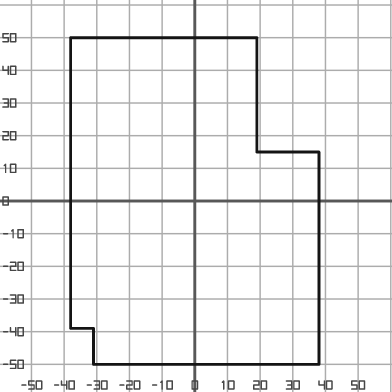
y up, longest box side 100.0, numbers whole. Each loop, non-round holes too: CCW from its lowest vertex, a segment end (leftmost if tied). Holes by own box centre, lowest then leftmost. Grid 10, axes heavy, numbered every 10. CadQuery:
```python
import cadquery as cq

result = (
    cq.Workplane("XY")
    .moveTo(-31.0, -50.0)
    .lineTo(38.0, -50.0)
    .lineTo(38.0, 15.0)
    .lineTo(19.0, 15.0)
    .lineTo(19.0, 50.0)
    .lineTo(-38.0, 50.0)
    .lineTo(-38.0, -39.0)
    .lineTo(-31.0, -39.0)
    .close()
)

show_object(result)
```